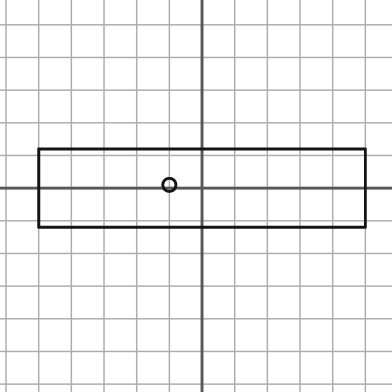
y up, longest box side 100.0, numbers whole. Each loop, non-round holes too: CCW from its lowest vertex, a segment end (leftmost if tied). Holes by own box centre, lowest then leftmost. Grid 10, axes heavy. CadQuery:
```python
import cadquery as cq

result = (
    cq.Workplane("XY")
    .moveTo(-50.0, -12.0)
    .lineTo(50.0, -12.0)
    .lineTo(50.0, 12.0)
    .lineTo(-50.0, 12.0)
    .close()
    .moveTo(-10.0, 1.0)
    .circle(2.0)
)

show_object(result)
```